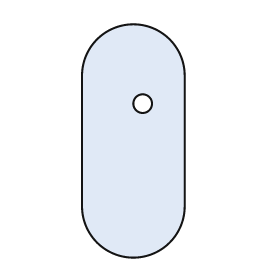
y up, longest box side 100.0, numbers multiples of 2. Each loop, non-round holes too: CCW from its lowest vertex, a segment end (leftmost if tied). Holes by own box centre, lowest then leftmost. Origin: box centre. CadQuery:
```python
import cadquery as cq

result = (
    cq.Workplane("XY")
    .moveTo(-22.0, -28.0)
    .threePointArc((0.0, -50.0), (22.0, -28.0))
    .lineTo(22.0, 28.0)
    .threePointArc((0.0, 50.0), (-22.0, 28.0))
    .close()
    .moveTo(4.0, 16.0)
    .circle(4.0)
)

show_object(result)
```